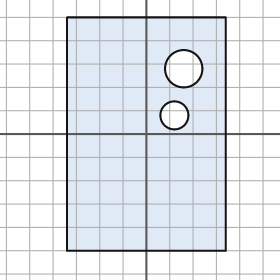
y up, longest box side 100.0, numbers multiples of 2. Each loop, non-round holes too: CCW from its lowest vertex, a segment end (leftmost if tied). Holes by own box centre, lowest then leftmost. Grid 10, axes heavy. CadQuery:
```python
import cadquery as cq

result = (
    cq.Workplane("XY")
    .moveTo(-34.0, -50.0)
    .lineTo(34.0, -50.0)
    .lineTo(34.0, 50.0)
    .lineTo(-34.0, 50.0)
    .close()
    .moveTo(12.0, 8.0)
    .circle(6.0)
    .moveTo(16.0, 28.0)
    .circle(8.0)
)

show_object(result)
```